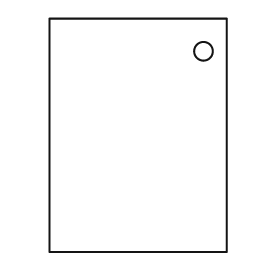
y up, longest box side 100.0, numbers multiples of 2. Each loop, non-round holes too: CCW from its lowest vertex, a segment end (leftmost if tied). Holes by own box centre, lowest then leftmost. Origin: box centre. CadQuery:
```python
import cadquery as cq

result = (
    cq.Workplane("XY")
    .moveTo(-38.0, -50.0)
    .lineTo(38.0, -50.0)
    .lineTo(38.0, 50.0)
    .lineTo(-38.0, 50.0)
    .close()
    .moveTo(28.0, 36.0)
    .circle(4.0)
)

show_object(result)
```